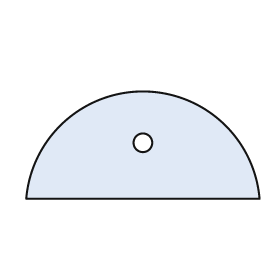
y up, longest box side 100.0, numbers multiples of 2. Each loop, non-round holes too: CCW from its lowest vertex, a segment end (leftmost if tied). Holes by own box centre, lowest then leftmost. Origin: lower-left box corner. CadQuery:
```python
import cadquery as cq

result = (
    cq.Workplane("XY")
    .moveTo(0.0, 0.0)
    .lineTo(100.0, 0.0)
    .threePointArc((50.0, 46.0), (0.0, 0.0))
    .close()
    .moveTo(50.0, 24.0)
    .circle(4.0)
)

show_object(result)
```